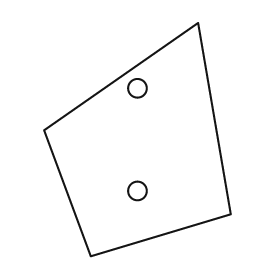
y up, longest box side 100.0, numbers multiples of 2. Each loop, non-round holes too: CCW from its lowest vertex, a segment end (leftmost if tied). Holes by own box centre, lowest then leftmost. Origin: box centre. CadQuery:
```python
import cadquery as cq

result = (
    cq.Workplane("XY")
    .moveTo(-20.0, -50.0)
    .lineTo(40.0, -32.0)
    .lineTo(26.0, 50.0)
    .lineTo(-40.0, 4.0)
    .close()
    .moveTo(0.0, -22.0)
    .circle(4.0)
    .moveTo(0.0, 22.0)
    .circle(4.0)
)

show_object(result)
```